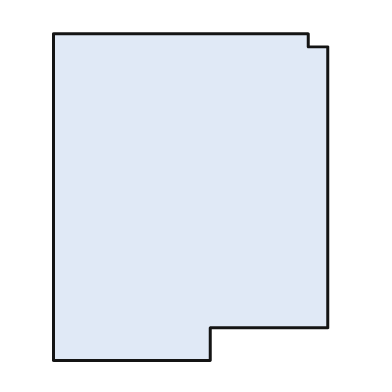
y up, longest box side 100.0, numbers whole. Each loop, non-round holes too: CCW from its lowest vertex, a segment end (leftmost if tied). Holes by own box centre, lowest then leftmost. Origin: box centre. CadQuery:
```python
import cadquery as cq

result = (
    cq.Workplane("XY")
    .moveTo(-42.0, -50.0)
    .lineTo(6.0, -50.0)
    .lineTo(6.0, -40.0)
    .lineTo(42.0, -40.0)
    .lineTo(42.0, 46.0)
    .lineTo(36.0, 46.0)
    .lineTo(36.0, 50.0)
    .lineTo(-42.0, 50.0)
    .close()
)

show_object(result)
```